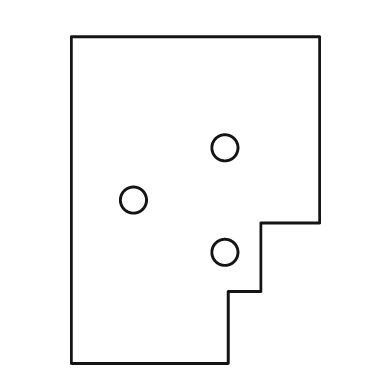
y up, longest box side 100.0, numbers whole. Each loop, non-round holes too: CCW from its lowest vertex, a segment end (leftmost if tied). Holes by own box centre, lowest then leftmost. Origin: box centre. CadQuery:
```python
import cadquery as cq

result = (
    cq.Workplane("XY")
    .moveTo(-38.0, -50.0)
    .lineTo(10.0, -50.0)
    .lineTo(10.0, -28.0)
    .lineTo(20.0, -28.0)
    .lineTo(20.0, -7.0)
    .lineTo(38.0, -7.0)
    .lineTo(38.0, 50.0)
    .lineTo(-38.0, 50.0)
    .close()
    .moveTo(9.0, -16.0)
    .circle(4.0)
    .moveTo(-19.0, 0.0)
    .circle(4.0)
    .moveTo(9.0, 16.0)
    .circle(4.0)
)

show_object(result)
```